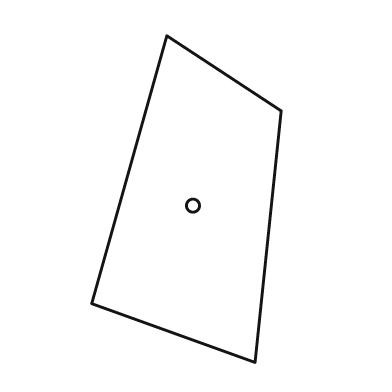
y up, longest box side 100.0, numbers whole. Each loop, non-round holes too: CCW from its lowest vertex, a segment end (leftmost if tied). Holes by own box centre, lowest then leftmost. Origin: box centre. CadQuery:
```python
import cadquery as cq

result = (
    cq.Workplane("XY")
    .moveTo(21.0, -50.0)
    .lineTo(29.0, 27.0)
    .lineTo(-6.0, 50.0)
    .lineTo(-29.0, -32.0)
    .close()
    .moveTo(2.0, -2.0)
    .circle(2.0)
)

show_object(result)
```